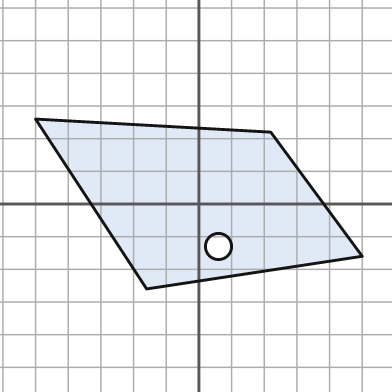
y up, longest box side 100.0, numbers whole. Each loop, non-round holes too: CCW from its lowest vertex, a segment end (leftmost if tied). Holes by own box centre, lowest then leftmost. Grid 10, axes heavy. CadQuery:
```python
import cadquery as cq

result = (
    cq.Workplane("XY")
    .moveTo(-16.0, -26.0)
    .lineTo(50.0, -16.0)
    .lineTo(22.0, 22.0)
    .lineTo(-50.0, 26.0)
    .close()
    .moveTo(6.0, -13.0)
    .circle(4.0)
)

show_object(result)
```